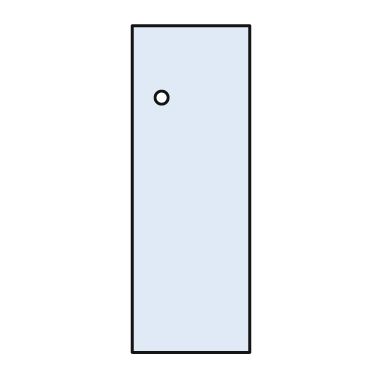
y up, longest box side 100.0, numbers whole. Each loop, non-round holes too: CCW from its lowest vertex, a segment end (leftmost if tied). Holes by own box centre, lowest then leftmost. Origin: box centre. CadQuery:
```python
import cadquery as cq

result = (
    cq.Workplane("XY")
    .moveTo(-18.0, -50.0)
    .lineTo(18.0, -50.0)
    .lineTo(18.0, 50.0)
    .lineTo(-18.0, 50.0)
    .close()
    .moveTo(-9.0, 28.0)
    .circle(2.0)
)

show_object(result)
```